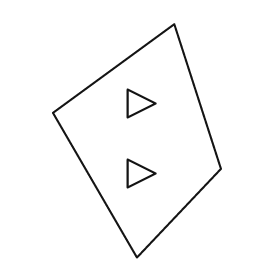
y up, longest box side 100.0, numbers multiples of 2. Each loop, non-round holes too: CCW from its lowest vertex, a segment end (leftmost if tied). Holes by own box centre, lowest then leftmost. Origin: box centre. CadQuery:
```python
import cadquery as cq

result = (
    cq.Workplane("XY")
    .moveTo(0.0, -50.0)
    .lineTo(36.0, -12.0)
    .lineTo(16.0, 50.0)
    .lineTo(-36.0, 12.0)
    .close()
    .moveTo(-4.0, -20.0)
    .lineTo(8.0, -14.0)
    .lineTo(-4.0, -8.0)
    .close()
    .moveTo(-4.0, 10.0)
    .lineTo(8.0, 16.0)
    .lineTo(-4.0, 22.0)
    .close()
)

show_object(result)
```